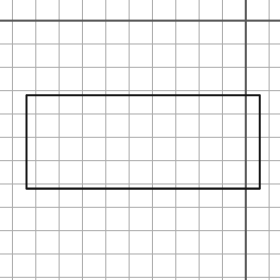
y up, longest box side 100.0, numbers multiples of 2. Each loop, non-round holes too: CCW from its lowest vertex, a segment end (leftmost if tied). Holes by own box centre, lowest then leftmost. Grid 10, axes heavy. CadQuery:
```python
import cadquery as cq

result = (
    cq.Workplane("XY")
    .moveTo(-94.0, -72.0)
    .lineTo(6.0, -72.0)
    .lineTo(6.0, -32.0)
    .lineTo(-94.0, -32.0)
    .close()
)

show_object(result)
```